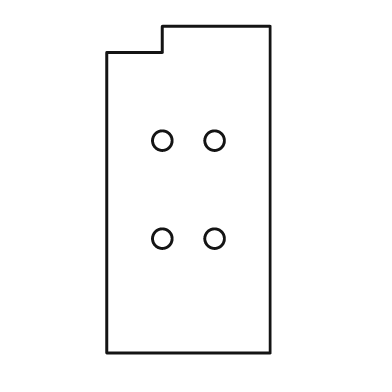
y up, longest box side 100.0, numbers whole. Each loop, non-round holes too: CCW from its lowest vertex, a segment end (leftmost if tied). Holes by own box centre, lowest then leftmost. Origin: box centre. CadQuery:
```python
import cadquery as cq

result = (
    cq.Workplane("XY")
    .moveTo(-25.0, -50.0)
    .lineTo(25.0, -50.0)
    .lineTo(25.0, 50.0)
    .lineTo(-8.0, 50.0)
    .lineTo(-8.0, 42.0)
    .lineTo(-25.0, 42.0)
    .close()
    .moveTo(-8.0, -15.0)
    .circle(3.0)
    .moveTo(8.0, -15.0)
    .circle(3.0)
    .moveTo(-8.0, 15.0)
    .circle(3.0)
    .moveTo(8.0, 15.0)
    .circle(3.0)
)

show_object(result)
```